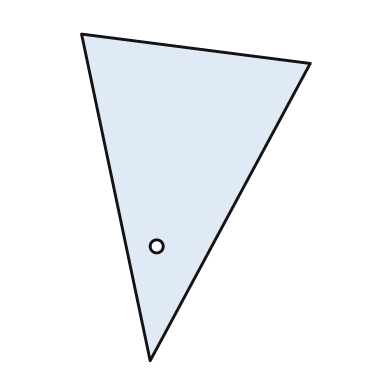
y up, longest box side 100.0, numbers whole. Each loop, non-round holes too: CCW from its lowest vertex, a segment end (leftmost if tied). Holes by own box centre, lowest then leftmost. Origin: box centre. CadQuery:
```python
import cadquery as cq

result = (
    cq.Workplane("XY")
    .moveTo(-14.0, -50.0)
    .lineTo(35.0, 41.0)
    .lineTo(-35.0, 50.0)
    .close()
    .moveTo(-12.0, -15.0)
    .circle(2.0)
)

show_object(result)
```